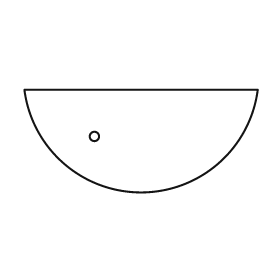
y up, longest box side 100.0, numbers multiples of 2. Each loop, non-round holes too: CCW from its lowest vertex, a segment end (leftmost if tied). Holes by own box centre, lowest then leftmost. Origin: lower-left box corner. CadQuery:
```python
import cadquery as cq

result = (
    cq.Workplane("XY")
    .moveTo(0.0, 44.0)
    .threePointArc((50.0, 0.0), (100.0, 44.0))
    .close()
    .moveTo(30.0, 24.0)
    .circle(2.0)
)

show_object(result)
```